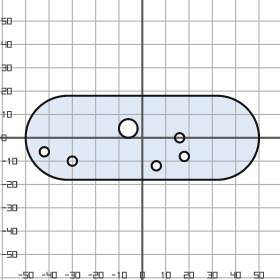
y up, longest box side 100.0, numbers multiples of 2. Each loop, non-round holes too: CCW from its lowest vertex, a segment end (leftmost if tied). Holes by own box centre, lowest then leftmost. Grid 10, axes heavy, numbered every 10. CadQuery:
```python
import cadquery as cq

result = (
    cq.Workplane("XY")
    .moveTo(-32.0, -18.0)
    .lineTo(32.0, -18.0)
    .threePointArc((50.0, 0.0), (32.0, 18.0))
    .lineTo(-32.0, 18.0)
    .threePointArc((-50.0, 0.0), (-32.0, -18.0))
    .close()
    .moveTo(6.0, -12.0)
    .circle(2.0)
    .moveTo(-30.0, -10.0)
    .circle(2.0)
    .moveTo(18.0, -8.0)
    .circle(2.0)
    .moveTo(-42.0, -6.0)
    .circle(2.0)
    .moveTo(16.0, 0.0)
    .circle(2.0)
    .moveTo(-6.0, 4.0)
    .circle(4.0)
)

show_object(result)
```